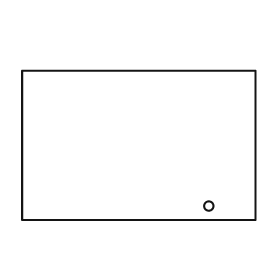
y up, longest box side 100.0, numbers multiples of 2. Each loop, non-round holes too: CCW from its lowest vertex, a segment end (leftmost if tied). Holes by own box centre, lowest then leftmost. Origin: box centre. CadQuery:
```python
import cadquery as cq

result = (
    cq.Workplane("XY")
    .moveTo(-50.0, -32.0)
    .lineTo(50.0, -32.0)
    .lineTo(50.0, 32.0)
    .lineTo(-50.0, 32.0)
    .close()
    .moveTo(30.0, -26.0)
    .circle(2.0)
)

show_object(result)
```